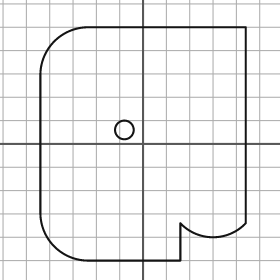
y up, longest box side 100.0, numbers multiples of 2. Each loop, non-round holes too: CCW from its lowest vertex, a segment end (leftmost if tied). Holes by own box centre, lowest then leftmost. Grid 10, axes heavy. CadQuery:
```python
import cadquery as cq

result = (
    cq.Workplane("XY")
    .moveTo(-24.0, -50.0)
    .lineTo(16.0, -50.0)
    .lineTo(16.0, -34.0)
    .threePointArc((30.0, -40.0), (44.0, -34.0))
    .lineTo(44.0, 50.0)
    .lineTo(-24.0, 50.0)
    .threePointArc((-38.0, 44.0), (-44.0, 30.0))
    .lineTo(-44.0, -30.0)
    .threePointArc((-38.0, -44.0), (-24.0, -50.0))
    .close()
    .moveTo(-8.0, 6.0)
    .circle(4.0)
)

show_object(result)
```